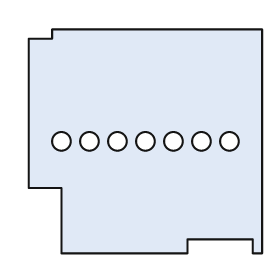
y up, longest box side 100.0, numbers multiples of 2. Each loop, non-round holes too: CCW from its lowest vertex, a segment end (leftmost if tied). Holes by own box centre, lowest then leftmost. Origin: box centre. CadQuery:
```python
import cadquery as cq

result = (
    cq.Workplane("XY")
    .moveTo(-36.0, -48.0)
    .lineTo(18.0, -48.0)
    .lineTo(18.0, -42.0)
    .lineTo(46.0, -42.0)
    .lineTo(46.0, -48.0)
    .lineTo(50.0, -48.0)
    .lineTo(50.0, 48.0)
    .lineTo(-40.0, 48.0)
    .lineTo(-40.0, 44.0)
    .lineTo(-50.0, 44.0)
    .lineTo(-50.0, -20.0)
    .lineTo(-36.0, -20.0)
    .close()
    .moveTo(-36.0, 0.0)
    .circle(4.0)
    .moveTo(-24.0, 0.0)
    .circle(4.0)
    .moveTo(-12.0, 0.0)
    .circle(4.0)
    .moveTo(0.0, 0.0)
    .circle(4.0)
    .moveTo(12.0, 0.0)
    .circle(4.0)
    .moveTo(24.0, 0.0)
    .circle(4.0)
    .moveTo(36.0, 0.0)
    .circle(4.0)
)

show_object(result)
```